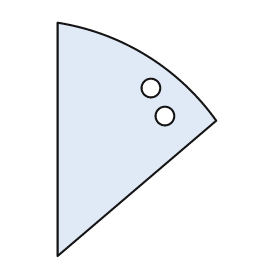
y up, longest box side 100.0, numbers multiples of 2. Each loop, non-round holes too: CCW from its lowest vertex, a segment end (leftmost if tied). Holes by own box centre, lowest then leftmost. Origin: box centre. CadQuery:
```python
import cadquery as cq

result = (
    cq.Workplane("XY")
    .moveTo(-34.0, -50.0)
    .lineTo(34.0, 8.0)
    .threePointArc((4.0, 36.0), (-34.0, 50.0))
    .close()
    .moveTo(12.0, 10.0)
    .circle(4.0)
    .moveTo(6.0, 22.0)
    .circle(4.0)
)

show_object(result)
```